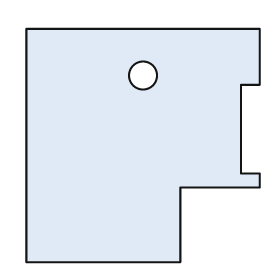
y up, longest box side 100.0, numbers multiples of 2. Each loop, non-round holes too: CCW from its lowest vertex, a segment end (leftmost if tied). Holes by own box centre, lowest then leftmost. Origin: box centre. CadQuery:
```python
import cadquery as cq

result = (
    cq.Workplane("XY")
    .moveTo(-50.0, -50.0)
    .lineTo(16.0, -50.0)
    .lineTo(16.0, -18.0)
    .lineTo(50.0, -18.0)
    .lineTo(50.0, -12.0)
    .lineTo(42.0, -12.0)
    .lineTo(42.0, 26.0)
    .lineTo(50.0, 26.0)
    .lineTo(50.0, 50.0)
    .lineTo(-50.0, 50.0)
    .close()
    .moveTo(0.0, 30.0)
    .circle(6.0)
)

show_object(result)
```